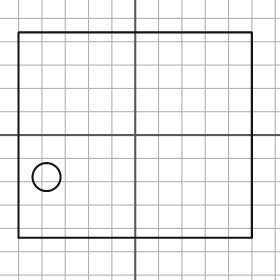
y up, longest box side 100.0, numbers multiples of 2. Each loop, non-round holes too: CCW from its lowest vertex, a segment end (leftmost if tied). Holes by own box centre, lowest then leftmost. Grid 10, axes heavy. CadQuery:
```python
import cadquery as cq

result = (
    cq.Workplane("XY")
    .moveTo(-50.0, -44.0)
    .lineTo(50.0, -44.0)
    .lineTo(50.0, 44.0)
    .lineTo(-50.0, 44.0)
    .close()
    .moveTo(-38.0, -18.0)
    .circle(6.0)
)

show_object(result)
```